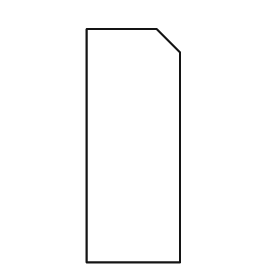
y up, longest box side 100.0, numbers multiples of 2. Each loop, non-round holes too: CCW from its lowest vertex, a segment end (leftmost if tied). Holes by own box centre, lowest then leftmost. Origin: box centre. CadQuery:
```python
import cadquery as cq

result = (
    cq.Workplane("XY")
    .moveTo(-20.0, -50.0)
    .lineTo(20.0, -50.0)
    .lineTo(20.0, 40.0)
    .lineTo(10.0, 50.0)
    .lineTo(-20.0, 50.0)
    .close()
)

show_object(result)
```